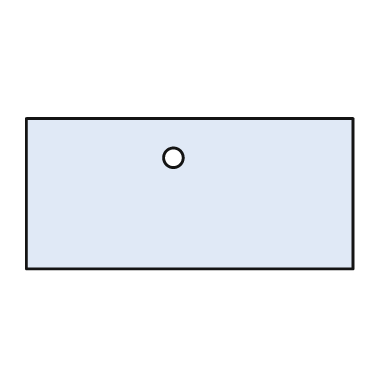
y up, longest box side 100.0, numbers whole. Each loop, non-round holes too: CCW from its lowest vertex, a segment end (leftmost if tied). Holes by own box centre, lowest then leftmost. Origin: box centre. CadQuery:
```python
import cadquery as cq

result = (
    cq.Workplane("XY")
    .moveTo(-50.0, -23.0)
    .lineTo(50.0, -23.0)
    .lineTo(50.0, 23.0)
    .lineTo(-50.0, 23.0)
    .close()
    .moveTo(-5.0, 11.0)
    .circle(3.0)
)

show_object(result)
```